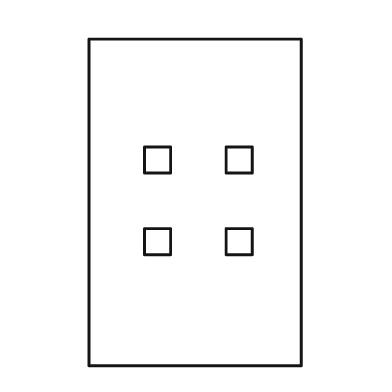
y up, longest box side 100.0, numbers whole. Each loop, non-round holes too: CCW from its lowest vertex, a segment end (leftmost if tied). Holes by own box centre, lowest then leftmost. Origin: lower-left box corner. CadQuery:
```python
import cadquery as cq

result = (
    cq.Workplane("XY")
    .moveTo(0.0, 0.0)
    .lineTo(65.0, 0.0)
    .lineTo(65.0, 100.0)
    .lineTo(0.0, 100.0)
    .close()
    .moveTo(17.0, 34.0)
    .lineTo(25.0, 34.0)
    .lineTo(25.0, 42.0)
    .lineTo(17.0, 42.0)
    .close()
    .moveTo(42.0, 34.0)
    .lineTo(50.0, 34.0)
    .lineTo(50.0, 42.0)
    .lineTo(42.0, 42.0)
    .close()
    .moveTo(17.0, 59.0)
    .lineTo(25.0, 59.0)
    .lineTo(25.0, 67.0)
    .lineTo(17.0, 67.0)
    .close()
    .moveTo(42.0, 59.0)
    .lineTo(50.0, 59.0)
    .lineTo(50.0, 67.0)
    .lineTo(42.0, 67.0)
    .close()
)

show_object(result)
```